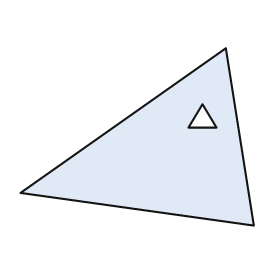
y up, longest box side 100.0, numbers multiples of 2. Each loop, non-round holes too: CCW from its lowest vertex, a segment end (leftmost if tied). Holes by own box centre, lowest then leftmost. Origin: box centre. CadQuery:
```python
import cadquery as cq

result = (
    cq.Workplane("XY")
    .moveTo(50.0, -38.0)
    .lineTo(38.0, 38.0)
    .lineTo(-50.0, -24.0)
    .close()
    .moveTo(22.0, 4.0)
    .lineTo(34.0, 4.0)
    .lineTo(28.0, 14.0)
    .close()
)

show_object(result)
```